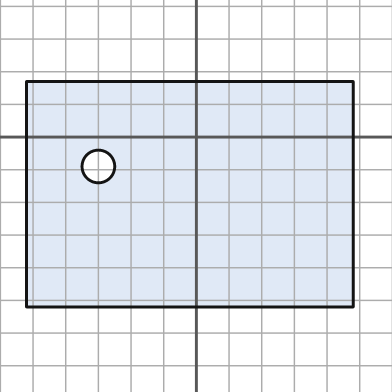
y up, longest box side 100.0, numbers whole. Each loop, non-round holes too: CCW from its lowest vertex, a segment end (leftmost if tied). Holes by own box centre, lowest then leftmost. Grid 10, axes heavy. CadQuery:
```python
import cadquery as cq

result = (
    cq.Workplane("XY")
    .moveTo(-52.0, -52.0)
    .lineTo(48.0, -52.0)
    .lineTo(48.0, 17.0)
    .lineTo(-52.0, 17.0)
    .close()
    .moveTo(-30.0, -9.0)
    .circle(5.0)
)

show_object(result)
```